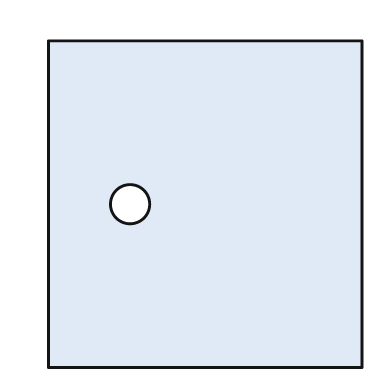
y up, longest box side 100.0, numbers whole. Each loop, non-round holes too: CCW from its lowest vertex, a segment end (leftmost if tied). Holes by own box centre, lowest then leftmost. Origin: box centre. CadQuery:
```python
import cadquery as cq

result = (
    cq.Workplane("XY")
    .moveTo(-48.0, -50.0)
    .lineTo(48.0, -50.0)
    .lineTo(48.0, 50.0)
    .lineTo(-48.0, 50.0)
    .close()
    .moveTo(-23.0, 0.0)
    .circle(6.0)
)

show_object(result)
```